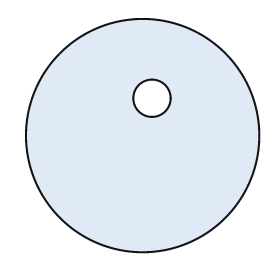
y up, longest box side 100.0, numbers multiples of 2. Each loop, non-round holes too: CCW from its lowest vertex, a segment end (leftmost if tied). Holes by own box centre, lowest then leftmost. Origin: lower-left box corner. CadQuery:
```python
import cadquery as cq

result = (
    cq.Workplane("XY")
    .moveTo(50.0, 50.0)
    .circle(50.0)
    .moveTo(54.0, 66.0)
    .circle(8.0)
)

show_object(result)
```